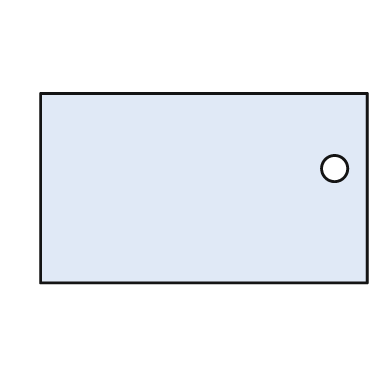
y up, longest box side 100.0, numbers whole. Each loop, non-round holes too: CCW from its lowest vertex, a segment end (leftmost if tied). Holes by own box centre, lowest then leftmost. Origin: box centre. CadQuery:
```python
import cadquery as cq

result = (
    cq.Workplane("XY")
    .moveTo(-50.0, -29.0)
    .lineTo(50.0, -29.0)
    .lineTo(50.0, 29.0)
    .lineTo(-50.0, 29.0)
    .close()
    .moveTo(40.0, 6.0)
    .circle(4.0)
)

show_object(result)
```